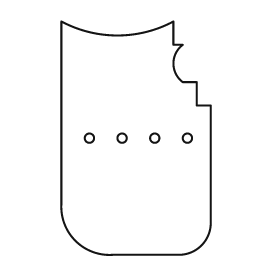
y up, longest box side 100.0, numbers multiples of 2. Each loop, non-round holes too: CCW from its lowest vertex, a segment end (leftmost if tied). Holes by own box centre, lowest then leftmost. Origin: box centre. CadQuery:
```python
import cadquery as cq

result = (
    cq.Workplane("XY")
    .moveTo(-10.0, -50.0)
    .lineTo(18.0, -50.0)
    .threePointArc((28.0, -46.0), (32.0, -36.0))
    .lineTo(32.0, 14.0)
    .lineTo(26.0, 14.0)
    .lineTo(26.0, 24.0)
    .lineTo(20.0, 24.0)
    .threePointArc((16.0, 32.0), (20.0, 40.0))
    .lineTo(16.0, 40.0)
    .lineTo(16.0, 50.0)
    .threePointArc((-8.0, 44.0), (-32.0, 50.0))
    .lineTo(-32.0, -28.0)
    .threePointArc((-26.0, -44.0), (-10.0, -50.0))
    .close()
    .moveTo(-20.0, 0.0)
    .circle(2.0)
    .moveTo(-6.0, 0.0)
    .circle(2.0)
    .moveTo(8.0, 0.0)
    .circle(2.0)
    .moveTo(22.0, 0.0)
    .circle(2.0)
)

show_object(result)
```